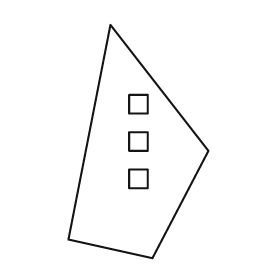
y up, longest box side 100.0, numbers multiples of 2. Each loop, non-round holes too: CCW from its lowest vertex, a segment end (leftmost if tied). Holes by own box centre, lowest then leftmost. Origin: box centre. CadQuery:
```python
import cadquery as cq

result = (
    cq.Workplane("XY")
    .moveTo(6.0, -50.0)
    .lineTo(30.0, -4.0)
    .lineTo(-12.0, 50.0)
    .lineTo(-30.0, -42.0)
    .close()
    .moveTo(-4.0, -20.0)
    .lineTo(4.0, -20.0)
    .lineTo(4.0, -12.0)
    .lineTo(-4.0, -12.0)
    .close()
    .moveTo(-4.0, -4.0)
    .lineTo(4.0, -4.0)
    .lineTo(4.0, 4.0)
    .lineTo(-4.0, 4.0)
    .close()
    .moveTo(-4.0, 12.0)
    .lineTo(4.0, 12.0)
    .lineTo(4.0, 20.0)
    .lineTo(-4.0, 20.0)
    .close()
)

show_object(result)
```